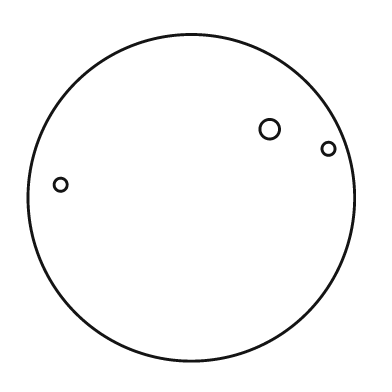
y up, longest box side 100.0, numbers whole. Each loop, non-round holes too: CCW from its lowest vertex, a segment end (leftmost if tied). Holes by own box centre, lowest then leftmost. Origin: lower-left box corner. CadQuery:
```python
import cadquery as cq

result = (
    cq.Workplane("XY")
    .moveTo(50.0, 50.0)
    .circle(50.0)
    .moveTo(10.0, 54.0)
    .circle(2.0)
    .moveTo(92.0, 65.0)
    .circle(2.0)
    .moveTo(74.0, 71.0)
    .circle(3.0)
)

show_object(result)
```